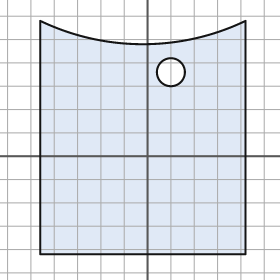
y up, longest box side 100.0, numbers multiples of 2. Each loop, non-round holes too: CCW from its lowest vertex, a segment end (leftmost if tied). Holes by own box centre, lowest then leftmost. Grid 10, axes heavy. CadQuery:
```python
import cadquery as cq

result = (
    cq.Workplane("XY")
    .moveTo(-46.0, -42.0)
    .lineTo(42.0, -42.0)
    .lineTo(42.0, 58.0)
    .threePointArc((-2.0, 48.0), (-46.0, 58.0))
    .close()
    .moveTo(10.0, 36.0)
    .circle(6.0)
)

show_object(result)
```